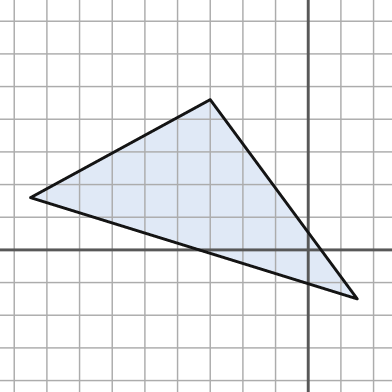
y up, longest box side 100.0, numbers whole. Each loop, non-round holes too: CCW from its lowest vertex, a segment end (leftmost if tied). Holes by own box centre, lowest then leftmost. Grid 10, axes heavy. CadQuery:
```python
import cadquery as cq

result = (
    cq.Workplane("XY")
    .moveTo(15.0, -15.0)
    .lineTo(-30.0, 46.0)
    .lineTo(-85.0, 16.0)
    .close()
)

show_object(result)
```